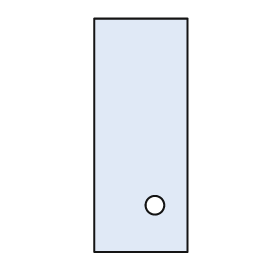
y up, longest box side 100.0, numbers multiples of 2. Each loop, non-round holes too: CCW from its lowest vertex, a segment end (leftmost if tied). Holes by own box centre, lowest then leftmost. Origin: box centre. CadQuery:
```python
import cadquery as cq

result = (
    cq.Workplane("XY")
    .moveTo(-20.0, -50.0)
    .lineTo(20.0, -50.0)
    .lineTo(20.0, 50.0)
    .lineTo(-20.0, 50.0)
    .close()
    .moveTo(6.0, -30.0)
    .circle(4.0)
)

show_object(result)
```